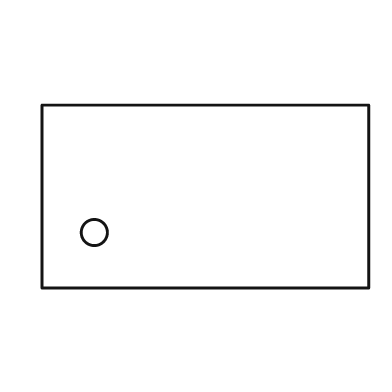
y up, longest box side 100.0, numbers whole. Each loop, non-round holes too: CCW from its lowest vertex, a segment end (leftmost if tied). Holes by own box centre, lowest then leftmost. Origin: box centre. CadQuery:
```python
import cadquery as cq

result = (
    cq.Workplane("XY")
    .moveTo(-50.0, -28.0)
    .lineTo(50.0, -28.0)
    .lineTo(50.0, 28.0)
    .lineTo(-50.0, 28.0)
    .close()
    .moveTo(-34.0, -11.0)
    .circle(4.0)
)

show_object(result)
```